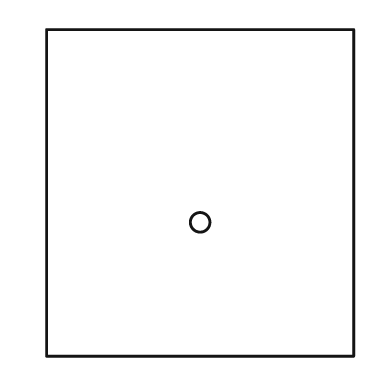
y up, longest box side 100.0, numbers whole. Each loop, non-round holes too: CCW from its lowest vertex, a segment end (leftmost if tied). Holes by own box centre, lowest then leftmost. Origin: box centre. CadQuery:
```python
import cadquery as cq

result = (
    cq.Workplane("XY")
    .moveTo(-47.0, -50.0)
    .lineTo(47.0, -50.0)
    .lineTo(47.0, 50.0)
    .lineTo(-47.0, 50.0)
    .close()
    .moveTo(0.0, -9.0)
    .circle(3.0)
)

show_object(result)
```